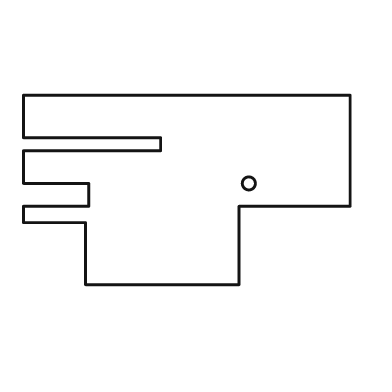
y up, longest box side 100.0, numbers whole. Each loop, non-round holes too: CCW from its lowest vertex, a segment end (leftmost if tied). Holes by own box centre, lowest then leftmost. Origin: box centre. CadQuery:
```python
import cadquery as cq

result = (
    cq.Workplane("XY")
    .moveTo(-31.0, -29.0)
    .lineTo(16.0, -29.0)
    .lineTo(16.0, -5.0)
    .lineTo(50.0, -5.0)
    .lineTo(50.0, 29.0)
    .lineTo(-50.0, 29.0)
    .lineTo(-50.0, 16.0)
    .lineTo(-8.0, 16.0)
    .lineTo(-8.0, 12.0)
    .lineTo(-50.0, 12.0)
    .lineTo(-50.0, 2.0)
    .lineTo(-30.0, 2.0)
    .lineTo(-30.0, -5.0)
    .lineTo(-50.0, -5.0)
    .lineTo(-50.0, -10.0)
    .lineTo(-31.0, -10.0)
    .close()
    .moveTo(19.0, 2.0)
    .circle(2.0)
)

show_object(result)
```